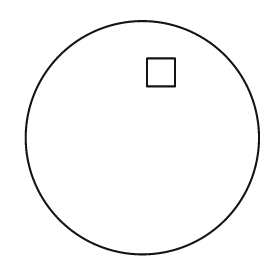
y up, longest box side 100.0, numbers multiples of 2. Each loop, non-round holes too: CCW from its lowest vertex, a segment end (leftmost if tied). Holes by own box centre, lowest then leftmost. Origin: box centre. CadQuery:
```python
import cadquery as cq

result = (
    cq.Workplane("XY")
    .moveTo(0.0, 0.0)
    .circle(50.0)
    .moveTo(2.0, 22.0)
    .lineTo(14.0, 22.0)
    .lineTo(14.0, 34.0)
    .lineTo(2.0, 34.0)
    .close()
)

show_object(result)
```